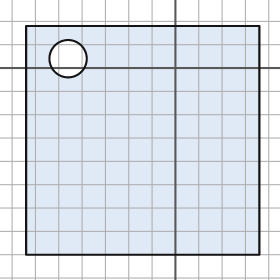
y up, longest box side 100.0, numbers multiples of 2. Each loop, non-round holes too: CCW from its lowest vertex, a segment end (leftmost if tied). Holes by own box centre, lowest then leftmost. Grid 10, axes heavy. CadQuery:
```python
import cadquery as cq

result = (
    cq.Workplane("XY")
    .moveTo(-64.0, -80.0)
    .lineTo(36.0, -80.0)
    .lineTo(36.0, 18.0)
    .lineTo(-64.0, 18.0)
    .close()
    .moveTo(-46.0, 4.0)
    .circle(8.0)
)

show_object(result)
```